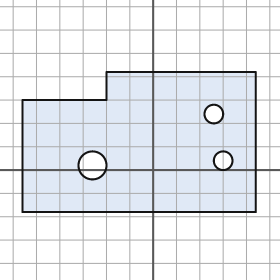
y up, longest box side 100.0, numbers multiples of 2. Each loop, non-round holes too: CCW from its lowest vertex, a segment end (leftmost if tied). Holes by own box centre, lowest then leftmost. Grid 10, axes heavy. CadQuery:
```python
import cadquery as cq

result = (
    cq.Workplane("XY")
    .moveTo(-56.0, -18.0)
    .lineTo(44.0, -18.0)
    .lineTo(44.0, 42.0)
    .lineTo(-20.0, 42.0)
    .lineTo(-20.0, 30.0)
    .lineTo(-56.0, 30.0)
    .close()
    .moveTo(-26.0, 2.0)
    .circle(6.0)
    .moveTo(30.0, 4.0)
    .circle(4.0)
    .moveTo(26.0, 24.0)
    .circle(4.0)
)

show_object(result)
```